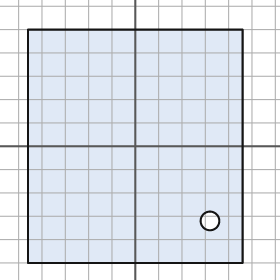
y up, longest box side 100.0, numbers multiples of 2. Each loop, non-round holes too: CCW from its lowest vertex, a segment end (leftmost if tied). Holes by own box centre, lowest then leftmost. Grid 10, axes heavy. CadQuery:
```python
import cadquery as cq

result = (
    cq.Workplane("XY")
    .moveTo(-46.0, -50.0)
    .lineTo(46.0, -50.0)
    .lineTo(46.0, 50.0)
    .lineTo(-46.0, 50.0)
    .close()
    .moveTo(32.0, -32.0)
    .circle(4.0)
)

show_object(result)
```